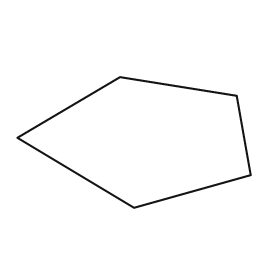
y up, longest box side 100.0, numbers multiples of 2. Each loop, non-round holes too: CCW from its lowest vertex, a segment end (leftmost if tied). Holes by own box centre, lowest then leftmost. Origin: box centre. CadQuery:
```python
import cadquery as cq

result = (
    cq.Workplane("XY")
    .moveTo(0.0, -28.0)
    .lineTo(50.0, -14.0)
    .lineTo(44.0, 20.0)
    .lineTo(-6.0, 28.0)
    .lineTo(-50.0, 2.0)
    .close()
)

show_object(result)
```